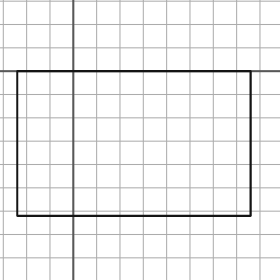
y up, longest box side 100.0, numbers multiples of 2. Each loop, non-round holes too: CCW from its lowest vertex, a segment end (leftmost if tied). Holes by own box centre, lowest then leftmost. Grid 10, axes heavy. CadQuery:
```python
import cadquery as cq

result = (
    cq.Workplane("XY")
    .moveTo(-24.0, -62.0)
    .lineTo(76.0, -62.0)
    .lineTo(76.0, 0.0)
    .lineTo(-24.0, 0.0)
    .close()
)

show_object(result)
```